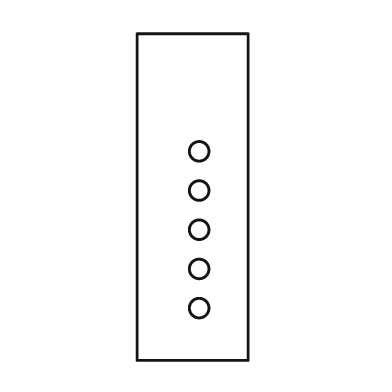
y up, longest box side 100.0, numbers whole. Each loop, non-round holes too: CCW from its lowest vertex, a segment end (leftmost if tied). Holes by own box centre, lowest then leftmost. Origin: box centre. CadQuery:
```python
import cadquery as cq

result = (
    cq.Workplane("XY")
    .moveTo(-17.0, -50.0)
    .lineTo(17.0, -50.0)
    .lineTo(17.0, 50.0)
    .lineTo(-17.0, 50.0)
    .close()
    .moveTo(2.0, -34.0)
    .circle(3.0)
    .moveTo(2.0, -22.0)
    .circle(3.0)
    .moveTo(2.0, -10.0)
    .circle(3.0)
    .moveTo(2.0, 2.0)
    .circle(3.0)
    .moveTo(2.0, 14.0)
    .circle(3.0)
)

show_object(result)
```